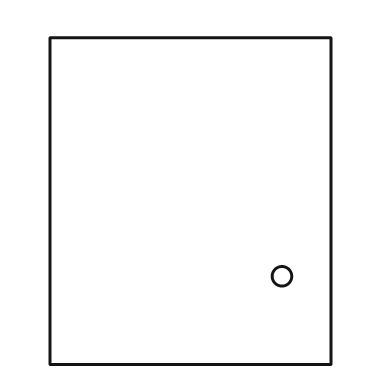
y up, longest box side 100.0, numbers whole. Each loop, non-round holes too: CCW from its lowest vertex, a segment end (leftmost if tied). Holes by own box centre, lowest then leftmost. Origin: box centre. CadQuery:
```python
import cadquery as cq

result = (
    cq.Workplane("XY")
    .moveTo(-43.0, -50.0)
    .lineTo(43.0, -50.0)
    .lineTo(43.0, 50.0)
    .lineTo(-43.0, 50.0)
    .close()
    .moveTo(28.0, -23.0)
    .circle(3.0)
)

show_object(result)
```